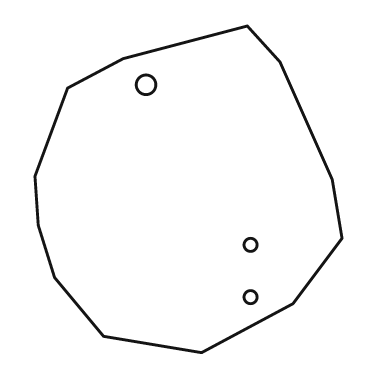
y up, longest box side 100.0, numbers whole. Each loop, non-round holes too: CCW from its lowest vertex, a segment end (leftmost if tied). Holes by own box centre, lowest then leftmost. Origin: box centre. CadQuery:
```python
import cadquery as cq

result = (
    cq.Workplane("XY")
    .moveTo(4.0, -50.0)
    .lineTo(32.0, -35.0)
    .lineTo(47.0, -15.0)
    .lineTo(44.0, 3.0)
    .lineTo(28.0, 39.0)
    .lineTo(18.0, 50.0)
    .lineTo(-20.0, 40.0)
    .lineTo(-37.0, 31.0)
    .lineTo(-47.0, 4.0)
    .lineTo(-46.0, -11.0)
    .lineTo(-41.0, -27.0)
    .lineTo(-26.0, -45.0)
    .close()
    .moveTo(19.0, -33.0)
    .circle(2.0)
    .moveTo(19.0, -17.0)
    .circle(2.0)
    .moveTo(-13.0, 32.0)
    .circle(3.0)
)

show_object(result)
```